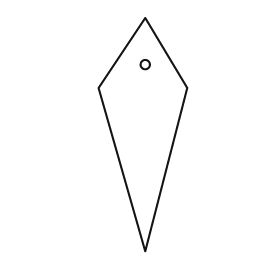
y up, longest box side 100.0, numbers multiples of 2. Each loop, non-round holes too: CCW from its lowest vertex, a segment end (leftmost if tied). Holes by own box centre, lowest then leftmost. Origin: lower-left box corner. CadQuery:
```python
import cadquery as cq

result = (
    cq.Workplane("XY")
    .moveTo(20.0, 0.0)
    .lineTo(38.0, 70.0)
    .lineTo(20.0, 100.0)
    .lineTo(0.0, 70.0)
    .close()
    .moveTo(20.0, 80.0)
    .circle(2.0)
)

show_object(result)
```